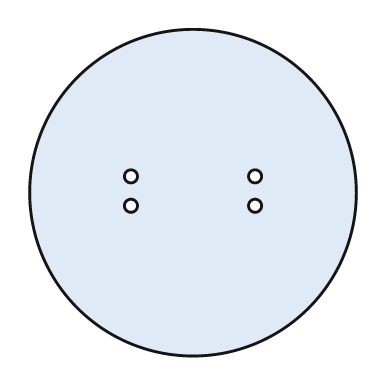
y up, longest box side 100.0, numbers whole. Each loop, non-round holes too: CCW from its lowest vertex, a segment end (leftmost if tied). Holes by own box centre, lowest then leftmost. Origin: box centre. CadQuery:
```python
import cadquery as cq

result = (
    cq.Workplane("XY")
    .moveTo(0.0, 0.0)
    .circle(50.0)
    .moveTo(-19.0, -4.0)
    .circle(2.0)
    .moveTo(19.0, -4.0)
    .circle(2.0)
    .moveTo(-19.0, 5.0)
    .circle(2.0)
    .moveTo(19.0, 5.0)
    .circle(2.0)
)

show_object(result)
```